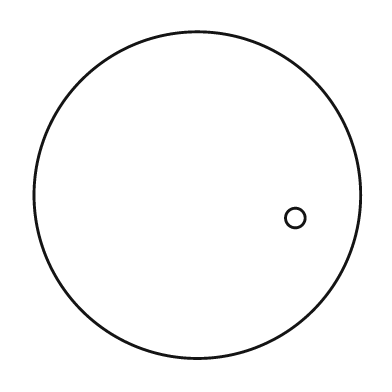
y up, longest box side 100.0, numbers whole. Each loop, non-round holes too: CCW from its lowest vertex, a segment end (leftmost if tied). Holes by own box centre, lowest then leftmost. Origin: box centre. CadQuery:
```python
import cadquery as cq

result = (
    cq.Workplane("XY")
    .moveTo(0.0, 0.0)
    .circle(50.0)
    .moveTo(30.0, -7.0)
    .circle(3.0)
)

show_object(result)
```